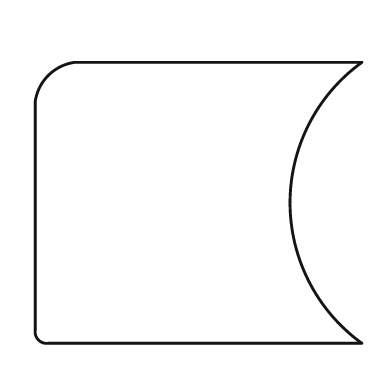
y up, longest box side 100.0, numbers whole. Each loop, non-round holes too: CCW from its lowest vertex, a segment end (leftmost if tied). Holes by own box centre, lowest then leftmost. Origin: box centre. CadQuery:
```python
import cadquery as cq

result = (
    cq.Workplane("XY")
    .moveTo(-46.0, -43.0)
    .lineTo(50.0, -43.0)
    .threePointArc((28.0, 0.0), (50.0, 43.0))
    .lineTo(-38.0, 43.0)
    .threePointArc((-46.0, 39.0), (-50.0, 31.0))
    .lineTo(-50.0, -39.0)
    .threePointArc((-49.0, -42.0), (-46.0, -43.0))
    .close()
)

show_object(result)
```